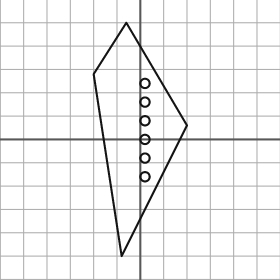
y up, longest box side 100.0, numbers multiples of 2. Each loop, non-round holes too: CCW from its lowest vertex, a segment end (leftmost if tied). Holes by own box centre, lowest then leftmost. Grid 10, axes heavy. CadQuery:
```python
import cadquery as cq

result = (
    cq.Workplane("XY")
    .moveTo(-8.0, -50.0)
    .lineTo(20.0, 6.0)
    .lineTo(-6.0, 50.0)
    .lineTo(-20.0, 28.0)
    .close()
    .moveTo(2.0, -16.0)
    .circle(2.0)
    .moveTo(2.0, -8.0)
    .circle(2.0)
    .moveTo(2.0, 0.0)
    .circle(2.0)
    .moveTo(2.0, 8.0)
    .circle(2.0)
    .moveTo(2.0, 16.0)
    .circle(2.0)
    .moveTo(2.0, 24.0)
    .circle(2.0)
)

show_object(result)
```